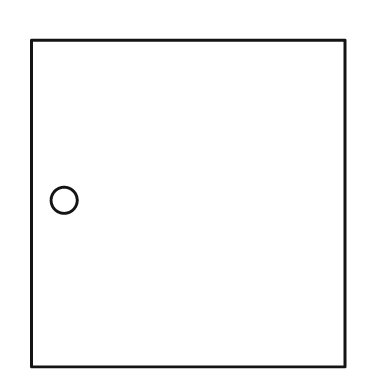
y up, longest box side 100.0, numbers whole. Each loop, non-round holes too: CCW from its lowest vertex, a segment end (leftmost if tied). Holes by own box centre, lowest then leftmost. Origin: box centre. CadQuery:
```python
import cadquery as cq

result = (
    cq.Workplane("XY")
    .moveTo(-48.0, -50.0)
    .lineTo(48.0, -50.0)
    .lineTo(48.0, 50.0)
    .lineTo(-48.0, 50.0)
    .close()
    .moveTo(-38.0, 1.0)
    .circle(4.0)
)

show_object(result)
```